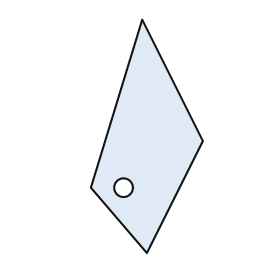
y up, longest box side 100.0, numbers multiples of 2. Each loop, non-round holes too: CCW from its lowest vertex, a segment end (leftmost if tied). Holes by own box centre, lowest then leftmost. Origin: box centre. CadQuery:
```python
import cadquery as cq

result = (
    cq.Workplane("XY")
    .moveTo(0.0, -50.0)
    .lineTo(24.0, -2.0)
    .lineTo(-2.0, 50.0)
    .lineTo(-24.0, -22.0)
    .close()
    .moveTo(-10.0, -22.0)
    .circle(4.0)
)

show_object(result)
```